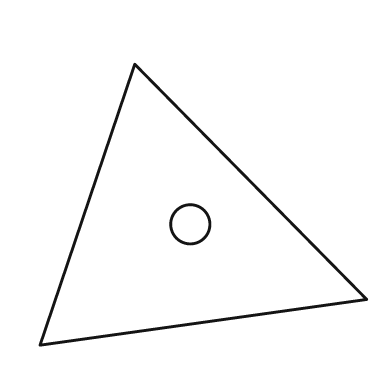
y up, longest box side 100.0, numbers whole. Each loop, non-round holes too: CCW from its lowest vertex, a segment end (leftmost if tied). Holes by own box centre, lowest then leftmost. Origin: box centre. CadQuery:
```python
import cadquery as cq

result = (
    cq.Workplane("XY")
    .moveTo(-50.0, -43.0)
    .lineTo(50.0, -29.0)
    .lineTo(-21.0, 43.0)
    .close()
    .moveTo(-4.0, -6.0)
    .circle(6.0)
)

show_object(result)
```